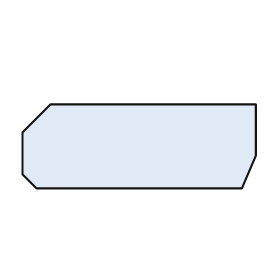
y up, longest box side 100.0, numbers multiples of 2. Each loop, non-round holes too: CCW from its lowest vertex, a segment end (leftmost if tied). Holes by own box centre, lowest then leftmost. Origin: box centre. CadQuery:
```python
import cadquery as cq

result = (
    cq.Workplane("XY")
    .moveTo(-44.0, -18.0)
    .lineTo(44.0, -18.0)
    .lineTo(50.0, -4.0)
    .lineTo(50.0, 18.0)
    .lineTo(-38.0, 18.0)
    .lineTo(-50.0, 6.0)
    .lineTo(-50.0, -12.0)
    .close()
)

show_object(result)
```